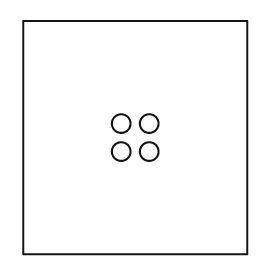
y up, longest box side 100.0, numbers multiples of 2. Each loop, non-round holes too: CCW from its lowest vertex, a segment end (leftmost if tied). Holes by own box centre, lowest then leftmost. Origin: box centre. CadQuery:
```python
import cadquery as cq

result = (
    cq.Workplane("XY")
    .moveTo(-48.0, -50.0)
    .lineTo(48.0, -50.0)
    .lineTo(48.0, 50.0)
    .lineTo(-48.0, 50.0)
    .close()
    .moveTo(-6.0, -6.0)
    .circle(4.0)
    .moveTo(6.0, -6.0)
    .circle(4.0)
    .moveTo(-6.0, 6.0)
    .circle(4.0)
    .moveTo(6.0, 6.0)
    .circle(4.0)
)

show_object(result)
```